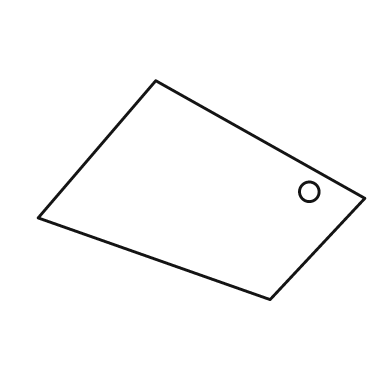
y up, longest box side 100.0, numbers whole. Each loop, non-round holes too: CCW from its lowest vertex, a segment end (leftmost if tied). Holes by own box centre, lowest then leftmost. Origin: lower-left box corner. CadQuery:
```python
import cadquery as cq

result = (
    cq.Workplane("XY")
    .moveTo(71.0, 0.0)
    .lineTo(100.0, 31.0)
    .lineTo(36.0, 67.0)
    .lineTo(0.0, 25.0)
    .close()
    .moveTo(83.0, 33.0)
    .circle(3.0)
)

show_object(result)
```